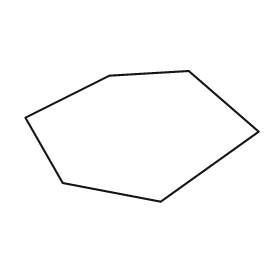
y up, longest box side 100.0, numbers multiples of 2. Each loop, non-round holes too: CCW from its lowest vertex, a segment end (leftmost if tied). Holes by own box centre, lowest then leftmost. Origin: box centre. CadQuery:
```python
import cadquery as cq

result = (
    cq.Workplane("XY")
    .moveTo(8.0, -28.0)
    .lineTo(50.0, 2.0)
    .lineTo(20.0, 28.0)
    .lineTo(-14.0, 26.0)
    .lineTo(-50.0, 8.0)
    .lineTo(-34.0, -20.0)
    .close()
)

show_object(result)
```